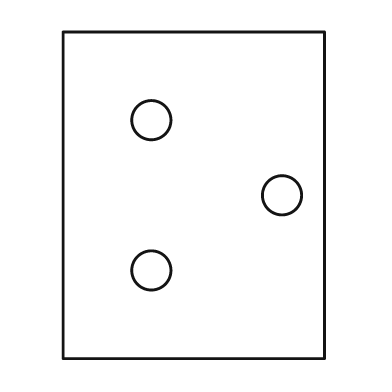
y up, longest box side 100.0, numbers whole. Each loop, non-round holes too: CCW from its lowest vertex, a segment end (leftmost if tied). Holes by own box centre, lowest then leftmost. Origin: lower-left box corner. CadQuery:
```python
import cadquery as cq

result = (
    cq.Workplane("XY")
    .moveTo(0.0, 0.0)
    .lineTo(80.0, 0.0)
    .lineTo(80.0, 100.0)
    .lineTo(0.0, 100.0)
    .close()
    .moveTo(27.0, 27.0)
    .circle(6.0)
    .moveTo(67.0, 50.0)
    .circle(6.0)
    .moveTo(27.0, 73.0)
    .circle(6.0)
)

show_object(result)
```